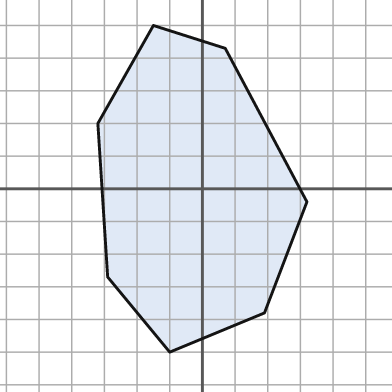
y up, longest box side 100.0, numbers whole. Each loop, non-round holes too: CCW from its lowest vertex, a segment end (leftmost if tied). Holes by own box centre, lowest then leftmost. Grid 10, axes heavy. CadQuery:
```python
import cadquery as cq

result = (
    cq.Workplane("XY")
    .moveTo(-10.0, -50.0)
    .lineTo(19.0, -38.0)
    .lineTo(32.0, -4.0)
    .lineTo(7.0, 43.0)
    .lineTo(-15.0, 50.0)
    .lineTo(-32.0, 20.0)
    .lineTo(-29.0, -27.0)
    .close()
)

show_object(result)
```